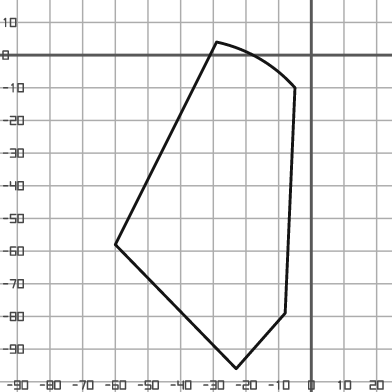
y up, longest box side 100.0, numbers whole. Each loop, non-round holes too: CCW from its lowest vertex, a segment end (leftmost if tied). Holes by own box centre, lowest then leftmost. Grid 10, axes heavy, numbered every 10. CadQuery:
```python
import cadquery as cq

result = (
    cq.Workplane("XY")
    .moveTo(-23.0, -96.0)
    .lineTo(-8.0, -79.0)
    .lineTo(-5.0, -10.0)
    .threePointArc((-16.0, -1.0), (-29.0, 4.0))
    .lineTo(-60.0, -58.0)
    .close()
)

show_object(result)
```